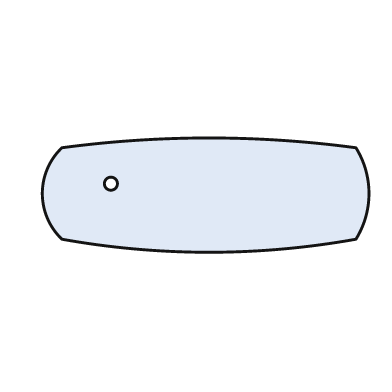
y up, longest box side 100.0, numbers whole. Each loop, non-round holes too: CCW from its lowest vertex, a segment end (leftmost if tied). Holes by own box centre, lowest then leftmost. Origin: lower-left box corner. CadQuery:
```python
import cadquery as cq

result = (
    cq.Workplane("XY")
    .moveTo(6.0, 4.0)
    .threePointArc((51.0, 0.0), (96.0, 4.0))
    .threePointArc((100.0, 18.0), (96.0, 32.0))
    .threePointArc((51.0, 35.0), (6.0, 32.0))
    .threePointArc((0.0, 18.0), (6.0, 4.0))
    .close()
    .moveTo(21.0, 21.0)
    .circle(2.0)
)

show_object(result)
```